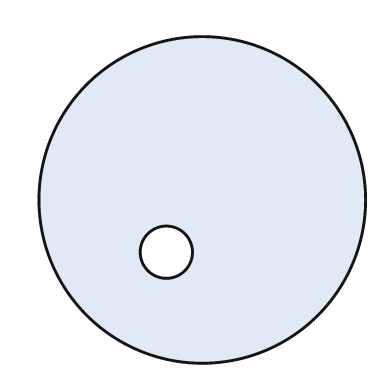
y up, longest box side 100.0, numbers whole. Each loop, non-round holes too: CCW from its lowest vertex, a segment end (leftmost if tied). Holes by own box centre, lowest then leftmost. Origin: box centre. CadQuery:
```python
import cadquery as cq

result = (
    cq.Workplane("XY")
    .moveTo(0.0, 0.0)
    .circle(50.0)
    .moveTo(-11.0, -16.0)
    .circle(8.0)
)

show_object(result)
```